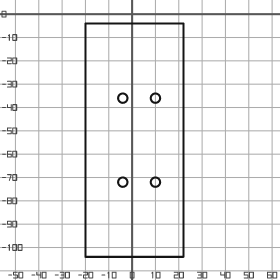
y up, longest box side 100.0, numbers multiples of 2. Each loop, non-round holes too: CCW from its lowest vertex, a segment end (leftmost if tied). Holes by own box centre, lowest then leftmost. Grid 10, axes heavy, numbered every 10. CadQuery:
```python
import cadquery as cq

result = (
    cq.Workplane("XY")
    .moveTo(-20.0, -104.0)
    .lineTo(22.0, -104.0)
    .lineTo(22.0, -4.0)
    .lineTo(-20.0, -4.0)
    .close()
    .moveTo(-4.0, -72.0)
    .circle(2.0)
    .moveTo(10.0, -72.0)
    .circle(2.0)
    .moveTo(-4.0, -36.0)
    .circle(2.0)
    .moveTo(10.0, -36.0)
    .circle(2.0)
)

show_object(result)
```